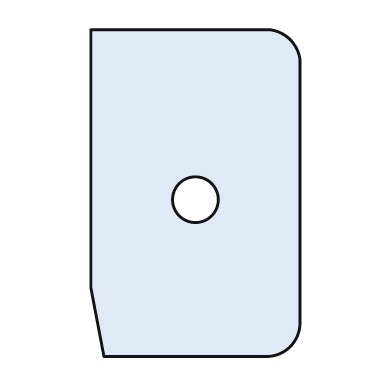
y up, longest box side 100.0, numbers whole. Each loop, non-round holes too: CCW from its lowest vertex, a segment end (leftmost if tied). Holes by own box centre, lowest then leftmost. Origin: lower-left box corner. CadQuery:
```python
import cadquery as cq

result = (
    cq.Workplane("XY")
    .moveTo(4.0, 0.0)
    .lineTo(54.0, 0.0)
    .threePointArc((61.0, 3.0), (64.0, 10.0))
    .lineTo(64.0, 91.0)
    .threePointArc((61.0, 97.0), (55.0, 100.0))
    .lineTo(0.0, 100.0)
    .lineTo(0.0, 21.0)
    .close()
    .moveTo(32.0, 48.0)
    .circle(7.0)
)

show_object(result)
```